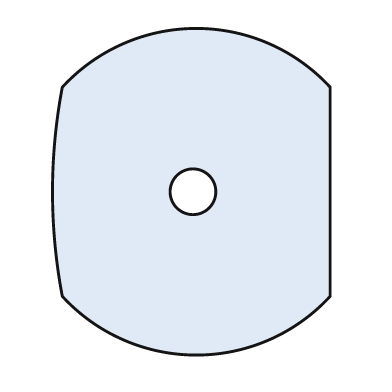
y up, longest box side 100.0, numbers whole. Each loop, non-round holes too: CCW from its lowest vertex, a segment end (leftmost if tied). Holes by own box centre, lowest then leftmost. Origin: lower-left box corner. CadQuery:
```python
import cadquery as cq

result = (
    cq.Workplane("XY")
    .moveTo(3.0, 18.0)
    .threePointArc((44.0, 0.0), (85.0, 18.0))
    .lineTo(85.0, 82.0)
    .threePointArc((44.0, 100.0), (3.0, 82.0))
    .threePointArc((0.0, 50.0), (3.0, 18.0))
    .close()
    .moveTo(43.0, 50.0)
    .circle(7.0)
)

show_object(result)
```